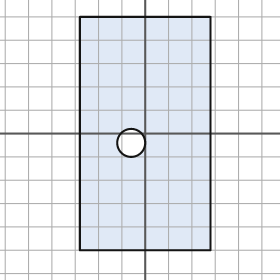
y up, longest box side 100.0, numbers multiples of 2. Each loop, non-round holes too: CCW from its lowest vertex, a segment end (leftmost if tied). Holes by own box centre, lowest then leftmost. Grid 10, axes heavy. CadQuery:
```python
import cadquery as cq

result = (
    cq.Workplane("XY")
    .moveTo(-28.0, -50.0)
    .lineTo(28.0, -50.0)
    .lineTo(28.0, 50.0)
    .lineTo(-28.0, 50.0)
    .close()
    .moveTo(-6.0, -4.0)
    .circle(6.0)
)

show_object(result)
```